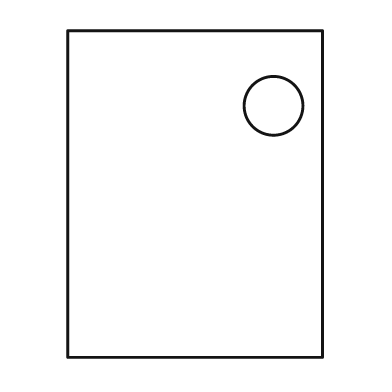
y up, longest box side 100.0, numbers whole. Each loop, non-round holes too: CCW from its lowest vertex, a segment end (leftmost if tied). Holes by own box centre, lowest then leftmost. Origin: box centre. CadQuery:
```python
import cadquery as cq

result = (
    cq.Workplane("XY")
    .moveTo(-39.0, -50.0)
    .lineTo(39.0, -50.0)
    .lineTo(39.0, 50.0)
    .lineTo(-39.0, 50.0)
    .close()
    .moveTo(24.0, 27.0)
    .circle(9.0)
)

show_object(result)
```